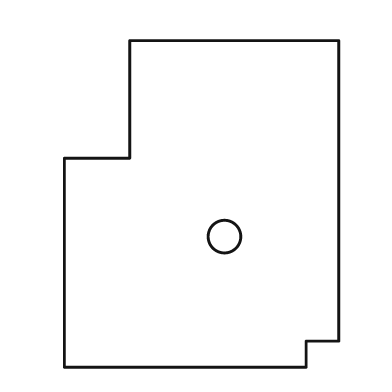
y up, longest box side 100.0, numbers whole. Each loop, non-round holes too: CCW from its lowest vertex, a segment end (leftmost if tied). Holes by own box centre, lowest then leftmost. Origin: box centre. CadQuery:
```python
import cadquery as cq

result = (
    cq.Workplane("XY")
    .moveTo(-42.0, -50.0)
    .lineTo(32.0, -50.0)
    .lineTo(32.0, -42.0)
    .lineTo(42.0, -42.0)
    .lineTo(42.0, 50.0)
    .lineTo(-22.0, 50.0)
    .lineTo(-22.0, 14.0)
    .lineTo(-42.0, 14.0)
    .close()
    .moveTo(7.0, -10.0)
    .circle(5.0)
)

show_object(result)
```